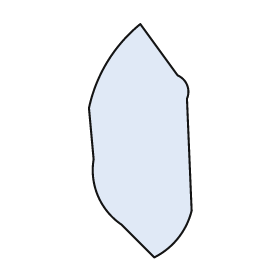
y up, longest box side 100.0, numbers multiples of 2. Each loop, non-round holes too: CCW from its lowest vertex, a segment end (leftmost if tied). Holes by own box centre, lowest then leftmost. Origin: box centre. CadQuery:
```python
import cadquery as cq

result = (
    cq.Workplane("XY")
    .moveTo(6.0, -50.0)
    .threePointArc((16.0, -42.0), (22.0, -30.0))
    .lineTo(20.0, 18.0)
    .threePointArc((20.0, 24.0), (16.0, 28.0))
    .lineTo(0.0, 50.0)
    .threePointArc((-14.0, 34.0), (-22.0, 14.0))
    .lineTo(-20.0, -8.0)
    .threePointArc((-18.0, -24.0), (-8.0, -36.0))
    .close()
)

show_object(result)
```